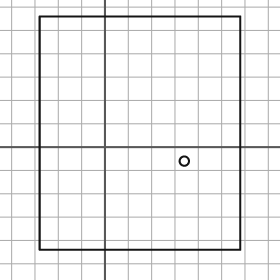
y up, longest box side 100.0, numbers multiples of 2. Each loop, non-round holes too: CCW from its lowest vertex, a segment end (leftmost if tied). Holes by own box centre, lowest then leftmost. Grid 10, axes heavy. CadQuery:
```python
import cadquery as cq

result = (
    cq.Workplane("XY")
    .moveTo(-28.0, -44.0)
    .lineTo(58.0, -44.0)
    .lineTo(58.0, 56.0)
    .lineTo(-28.0, 56.0)
    .close()
    .moveTo(34.0, -6.0)
    .circle(2.0)
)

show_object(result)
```